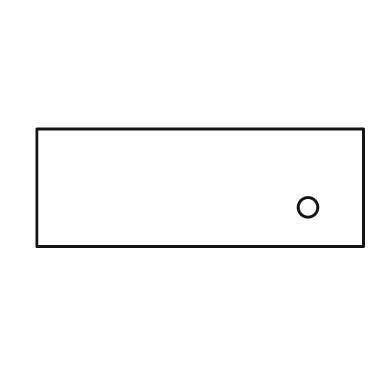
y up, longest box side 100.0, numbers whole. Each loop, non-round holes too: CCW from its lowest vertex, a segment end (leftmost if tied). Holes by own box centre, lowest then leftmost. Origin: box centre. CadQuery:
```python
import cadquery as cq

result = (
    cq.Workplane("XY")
    .moveTo(-50.0, -18.0)
    .lineTo(50.0, -18.0)
    .lineTo(50.0, 18.0)
    .lineTo(-50.0, 18.0)
    .close()
    .moveTo(33.0, -6.0)
    .circle(3.0)
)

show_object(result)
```